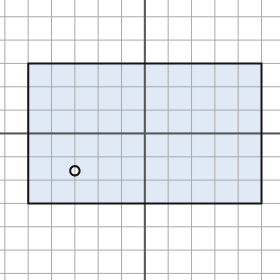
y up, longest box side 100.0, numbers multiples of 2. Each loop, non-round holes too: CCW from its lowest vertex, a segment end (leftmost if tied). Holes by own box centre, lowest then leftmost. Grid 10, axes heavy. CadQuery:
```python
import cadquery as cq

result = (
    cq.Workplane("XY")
    .moveTo(-50.0, -30.0)
    .lineTo(50.0, -30.0)
    .lineTo(50.0, 30.0)
    .lineTo(-50.0, 30.0)
    .close()
    .moveTo(-30.0, -16.0)
    .circle(2.0)
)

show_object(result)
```